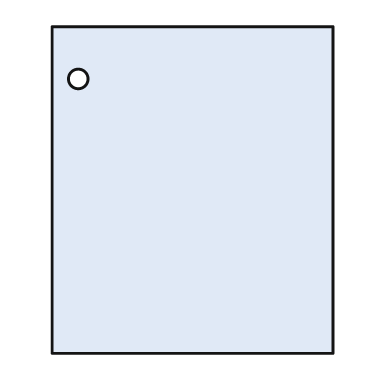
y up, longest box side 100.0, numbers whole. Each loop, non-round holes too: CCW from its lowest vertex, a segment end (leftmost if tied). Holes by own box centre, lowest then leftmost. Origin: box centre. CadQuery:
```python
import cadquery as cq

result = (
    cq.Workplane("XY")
    .moveTo(-43.0, -50.0)
    .lineTo(43.0, -50.0)
    .lineTo(43.0, 50.0)
    .lineTo(-43.0, 50.0)
    .close()
    .moveTo(-35.0, 34.0)
    .circle(3.0)
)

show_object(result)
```